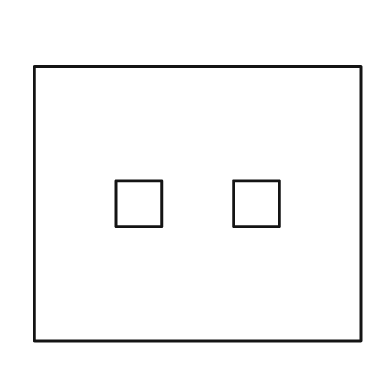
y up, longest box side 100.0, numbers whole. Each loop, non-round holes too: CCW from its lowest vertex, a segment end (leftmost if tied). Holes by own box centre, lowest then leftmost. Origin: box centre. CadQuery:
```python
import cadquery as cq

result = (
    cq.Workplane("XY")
    .moveTo(-50.0, -42.0)
    .lineTo(50.0, -42.0)
    .lineTo(50.0, 42.0)
    .lineTo(-50.0, 42.0)
    .close()
    .moveTo(-25.0, -7.0)
    .lineTo(-11.0, -7.0)
    .lineTo(-11.0, 7.0)
    .lineTo(-25.0, 7.0)
    .close()
    .moveTo(11.0, -7.0)
    .lineTo(25.0, -7.0)
    .lineTo(25.0, 7.0)
    .lineTo(11.0, 7.0)
    .close()
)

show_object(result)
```